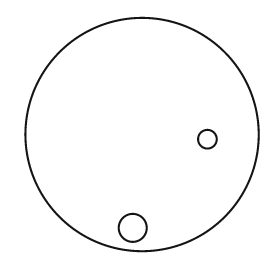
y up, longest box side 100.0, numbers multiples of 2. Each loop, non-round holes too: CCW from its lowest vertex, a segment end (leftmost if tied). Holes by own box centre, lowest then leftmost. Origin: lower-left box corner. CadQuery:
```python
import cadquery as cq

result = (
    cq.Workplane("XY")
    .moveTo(50.0, 50.0)
    .circle(50.0)
    .moveTo(46.0, 10.0)
    .circle(6.0)
    .moveTo(78.0, 48.0)
    .circle(4.0)
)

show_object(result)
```